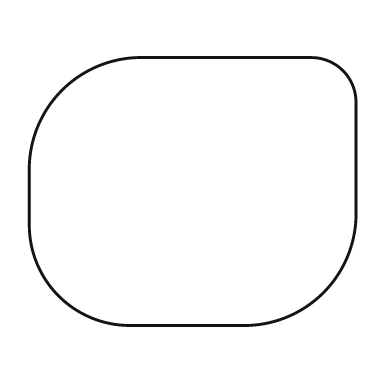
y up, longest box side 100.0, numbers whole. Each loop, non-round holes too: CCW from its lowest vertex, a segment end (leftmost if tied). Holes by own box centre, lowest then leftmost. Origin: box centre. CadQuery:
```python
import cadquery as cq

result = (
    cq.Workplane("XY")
    .moveTo(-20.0, -41.0)
    .lineTo(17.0, -41.0)
    .threePointArc((40.0, -31.0), (50.0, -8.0))
    .lineTo(50.0, 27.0)
    .threePointArc((46.0, 37.0), (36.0, 41.0))
    .lineTo(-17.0, 41.0)
    .threePointArc((-40.0, 31.0), (-50.0, 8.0))
    .lineTo(-50.0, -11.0)
    .threePointArc((-41.0, -32.0), (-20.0, -41.0))
    .close()
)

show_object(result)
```